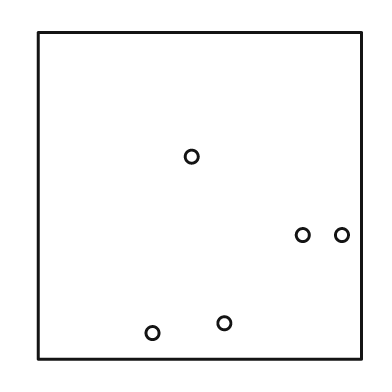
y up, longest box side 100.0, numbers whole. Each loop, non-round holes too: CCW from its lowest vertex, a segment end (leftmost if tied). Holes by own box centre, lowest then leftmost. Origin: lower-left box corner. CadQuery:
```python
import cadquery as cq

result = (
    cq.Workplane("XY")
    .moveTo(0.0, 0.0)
    .lineTo(99.0, 0.0)
    .lineTo(99.0, 100.0)
    .lineTo(0.0, 100.0)
    .close()
    .moveTo(35.0, 8.0)
    .circle(2.0)
    .moveTo(57.0, 11.0)
    .circle(2.0)
    .moveTo(81.0, 38.0)
    .circle(2.0)
    .moveTo(93.0, 38.0)
    .circle(2.0)
    .moveTo(47.0, 62.0)
    .circle(2.0)
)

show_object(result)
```